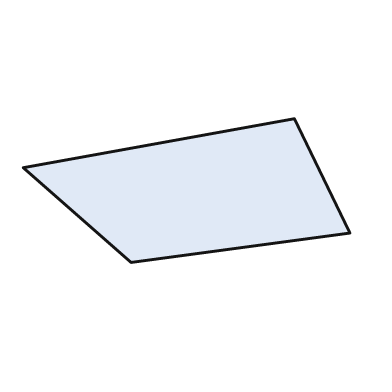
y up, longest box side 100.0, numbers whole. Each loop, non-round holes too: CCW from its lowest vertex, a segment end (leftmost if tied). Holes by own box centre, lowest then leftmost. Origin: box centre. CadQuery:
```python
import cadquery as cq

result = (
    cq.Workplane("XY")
    .moveTo(-17.0, -22.0)
    .lineTo(50.0, -13.0)
    .lineTo(33.0, 22.0)
    .lineTo(-50.0, 7.0)
    .close()
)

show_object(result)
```